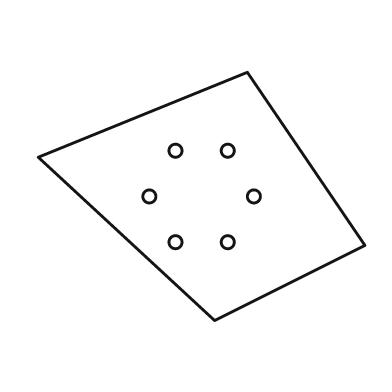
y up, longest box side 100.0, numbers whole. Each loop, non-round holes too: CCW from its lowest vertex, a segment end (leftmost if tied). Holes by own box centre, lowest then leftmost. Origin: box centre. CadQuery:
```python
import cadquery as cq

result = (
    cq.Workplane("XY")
    .moveTo(4.0, -38.0)
    .lineTo(50.0, -15.0)
    .lineTo(14.0, 38.0)
    .lineTo(-50.0, 12.0)
    .close()
    .moveTo(-8.0, -14.0)
    .circle(2.0)
    .moveTo(8.0, -14.0)
    .circle(2.0)
    .moveTo(-16.0, 0.0)
    .circle(2.0)
    .moveTo(16.0, 0.0)
    .circle(2.0)
    .moveTo(-8.0, 14.0)
    .circle(2.0)
    .moveTo(8.0, 14.0)
    .circle(2.0)
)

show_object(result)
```